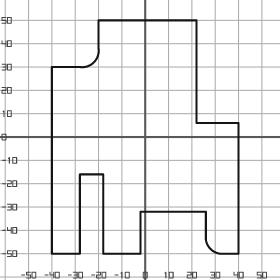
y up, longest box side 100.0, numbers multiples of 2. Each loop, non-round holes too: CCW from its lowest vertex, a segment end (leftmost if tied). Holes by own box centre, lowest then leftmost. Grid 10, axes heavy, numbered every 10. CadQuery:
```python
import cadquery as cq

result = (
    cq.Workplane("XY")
    .moveTo(-40.0, -50.0)
    .lineTo(-28.0, -50.0)
    .lineTo(-28.0, -16.0)
    .lineTo(-18.0, -16.0)
    .lineTo(-18.0, -50.0)
    .lineTo(-2.0, -50.0)
    .lineTo(-2.0, -32.0)
    .lineTo(26.0, -32.0)
    .lineTo(26.0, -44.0)
    .threePointArc((28.0, -48.0), (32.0, -50.0))
    .lineTo(40.0, -50.0)
    .lineTo(40.0, 6.0)
    .lineTo(22.0, 6.0)
    .lineTo(22.0, 50.0)
    .lineTo(-20.0, 50.0)
    .lineTo(-20.0, 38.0)
    .threePointArc((-22.0, 32.0), (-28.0, 30.0))
    .lineTo(-40.0, 30.0)
    .close()
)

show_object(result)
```